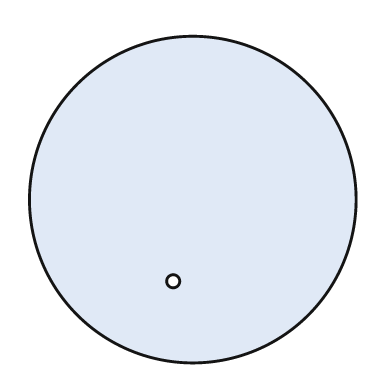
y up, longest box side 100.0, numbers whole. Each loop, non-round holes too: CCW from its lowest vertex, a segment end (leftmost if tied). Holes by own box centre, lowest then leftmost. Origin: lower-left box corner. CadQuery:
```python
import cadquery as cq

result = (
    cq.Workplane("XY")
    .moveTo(50.0, 50.0)
    .circle(50.0)
    .moveTo(44.0, 25.0)
    .circle(2.0)
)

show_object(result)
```